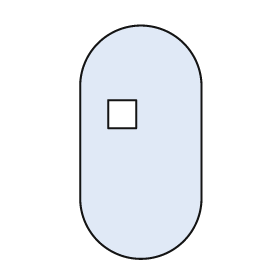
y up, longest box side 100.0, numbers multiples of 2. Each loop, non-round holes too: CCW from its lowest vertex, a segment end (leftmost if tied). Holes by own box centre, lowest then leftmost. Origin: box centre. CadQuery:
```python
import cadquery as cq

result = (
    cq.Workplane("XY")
    .moveTo(-26.0, -24.0)
    .threePointArc((0.0, -50.0), (26.0, -24.0))
    .lineTo(26.0, 24.0)
    .threePointArc((0.0, 50.0), (-26.0, 24.0))
    .close()
    .moveTo(-14.0, 6.0)
    .lineTo(-2.0, 6.0)
    .lineTo(-2.0, 18.0)
    .lineTo(-14.0, 18.0)
    .close()
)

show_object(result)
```